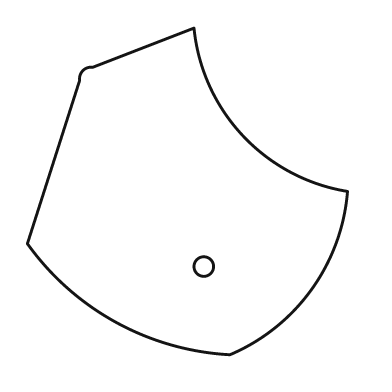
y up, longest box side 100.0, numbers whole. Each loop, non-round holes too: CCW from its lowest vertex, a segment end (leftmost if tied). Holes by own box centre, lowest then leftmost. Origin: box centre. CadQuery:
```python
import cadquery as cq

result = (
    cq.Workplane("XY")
    .moveTo(13.0, -50.0)
    .threePointArc((38.0, -30.0), (49.0, 0.0))
    .threePointArc((17.0, 17.0), (2.0, 50.0))
    .lineTo(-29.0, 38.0)
    .threePointArc((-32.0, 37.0), (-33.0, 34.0))
    .lineTo(-49.0, -16.0)
    .threePointArc((-22.0, -40.0), (13.0, -50.0))
    .close()
    .moveTo(5.0, -23.0)
    .circle(3.0)
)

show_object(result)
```